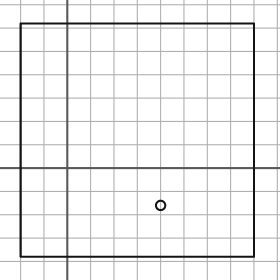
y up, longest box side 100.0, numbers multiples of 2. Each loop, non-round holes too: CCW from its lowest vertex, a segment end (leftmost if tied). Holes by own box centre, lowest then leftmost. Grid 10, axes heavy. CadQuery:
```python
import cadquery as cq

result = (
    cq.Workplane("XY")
    .moveTo(-20.0, -38.0)
    .lineTo(80.0, -38.0)
    .lineTo(80.0, 62.0)
    .lineTo(-20.0, 62.0)
    .close()
    .moveTo(40.0, -16.0)
    .circle(2.0)
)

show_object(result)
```